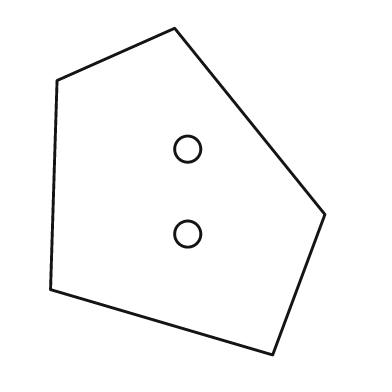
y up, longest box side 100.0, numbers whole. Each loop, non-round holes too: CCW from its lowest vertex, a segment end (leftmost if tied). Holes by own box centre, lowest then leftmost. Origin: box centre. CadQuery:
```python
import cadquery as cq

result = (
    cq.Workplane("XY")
    .moveTo(26.0, -50.0)
    .lineTo(42.0, -7.0)
    .lineTo(-4.0, 50.0)
    .lineTo(-40.0, 34.0)
    .lineTo(-42.0, -30.0)
    .close()
    .moveTo(0.0, -13.0)
    .circle(4.0)
    .moveTo(0.0, 13.0)
    .circle(4.0)
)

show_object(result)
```